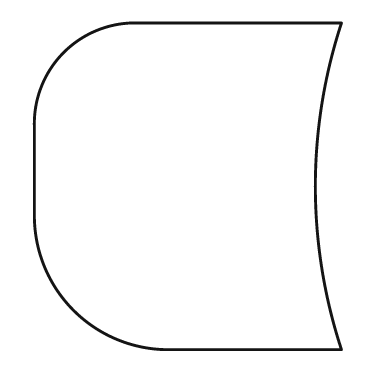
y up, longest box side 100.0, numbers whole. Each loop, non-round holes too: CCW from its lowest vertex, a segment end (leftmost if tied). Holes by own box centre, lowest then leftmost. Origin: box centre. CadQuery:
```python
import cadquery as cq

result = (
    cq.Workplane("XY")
    .moveTo(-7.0, -50.0)
    .lineTo(47.0, -50.0)
    .threePointArc((39.0, 0.0), (47.0, 50.0))
    .lineTo(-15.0, 50.0)
    .threePointArc((-38.0, 41.0), (-47.0, 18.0))
    .lineTo(-47.0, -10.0)
    .threePointArc((-35.0, -38.0), (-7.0, -50.0))
    .close()
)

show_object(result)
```